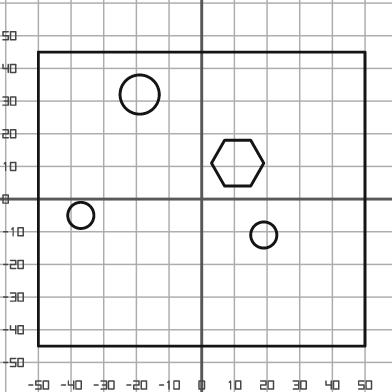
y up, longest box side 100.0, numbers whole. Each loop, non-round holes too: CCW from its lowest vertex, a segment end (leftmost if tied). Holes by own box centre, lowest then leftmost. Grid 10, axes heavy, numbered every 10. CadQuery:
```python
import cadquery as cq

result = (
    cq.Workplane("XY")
    .moveTo(-50.0, -45.0)
    .lineTo(50.0, -45.0)
    .lineTo(50.0, 45.0)
    .lineTo(-50.0, 45.0)
    .close()
    .moveTo(19.0, -11.0)
    .circle(4.0)
    .moveTo(-37.0, -5.0)
    .circle(4.0)
    .moveTo(7.0, 4.0)
    .lineTo(15.0, 4.0)
    .lineTo(19.0, 11.0)
    .lineTo(15.0, 18.0)
    .lineTo(7.0, 18.0)
    .lineTo(3.0, 11.0)
    .close()
    .moveTo(-19.0, 32.0)
    .circle(6.0)
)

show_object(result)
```